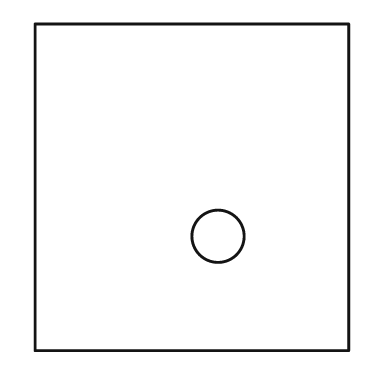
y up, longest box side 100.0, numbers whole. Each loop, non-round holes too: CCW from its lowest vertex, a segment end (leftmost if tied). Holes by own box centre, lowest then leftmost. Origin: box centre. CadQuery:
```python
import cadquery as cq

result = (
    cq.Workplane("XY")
    .moveTo(-48.0, -50.0)
    .lineTo(48.0, -50.0)
    .lineTo(48.0, 50.0)
    .lineTo(-48.0, 50.0)
    .close()
    .moveTo(8.0, -15.0)
    .circle(8.0)
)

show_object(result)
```